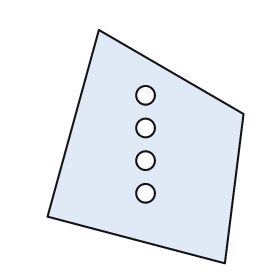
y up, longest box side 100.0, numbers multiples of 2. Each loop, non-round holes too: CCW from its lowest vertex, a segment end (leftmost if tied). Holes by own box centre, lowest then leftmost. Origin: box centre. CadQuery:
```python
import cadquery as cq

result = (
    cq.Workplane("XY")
    .moveTo(34.0, -50.0)
    .lineTo(42.0, 14.0)
    .lineTo(-20.0, 50.0)
    .lineTo(-42.0, -30.0)
    .close()
    .moveTo(0.0, -20.0)
    .circle(4.0)
    .moveTo(0.0, -6.0)
    .circle(4.0)
    .moveTo(0.0, 8.0)
    .circle(4.0)
    .moveTo(0.0, 22.0)
    .circle(4.0)
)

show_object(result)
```